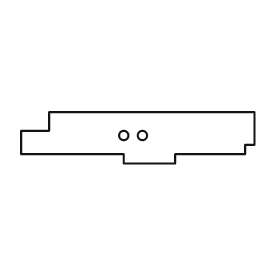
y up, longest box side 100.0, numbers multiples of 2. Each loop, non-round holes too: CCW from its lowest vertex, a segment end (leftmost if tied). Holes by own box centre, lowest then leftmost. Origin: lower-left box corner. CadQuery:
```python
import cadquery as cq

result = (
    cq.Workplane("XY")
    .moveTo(44.0, 0.0)
    .lineTo(66.0, 0.0)
    .lineTo(66.0, 4.0)
    .lineTo(96.0, 4.0)
    .lineTo(96.0, 8.0)
    .lineTo(100.0, 8.0)
    .lineTo(100.0, 22.0)
    .lineTo(12.0, 22.0)
    .lineTo(12.0, 14.0)
    .lineTo(0.0, 14.0)
    .lineTo(0.0, 4.0)
    .lineTo(44.0, 4.0)
    .close()
    .moveTo(44.0, 12.0)
    .circle(2.0)
    .moveTo(52.0, 12.0)
    .circle(2.0)
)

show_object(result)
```